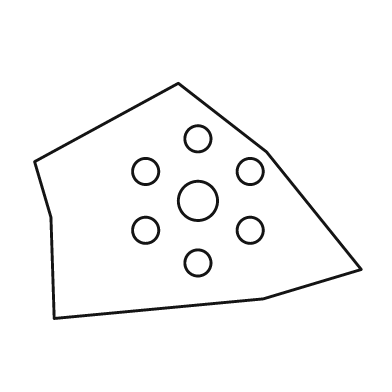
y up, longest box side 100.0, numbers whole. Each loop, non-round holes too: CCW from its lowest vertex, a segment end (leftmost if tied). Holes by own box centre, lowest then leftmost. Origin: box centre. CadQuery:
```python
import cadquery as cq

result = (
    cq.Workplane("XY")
    .moveTo(-44.0, -36.0)
    .lineTo(20.0, -30.0)
    .lineTo(50.0, -21.0)
    .lineTo(21.0, 15.0)
    .lineTo(-6.0, 36.0)
    .lineTo(-50.0, 12.0)
    .lineTo(-45.0, -5.0)
    .close()
    .moveTo(0.0, -19.0)
    .circle(4.0)
    .moveTo(-16.0, -9.0)
    .circle(4.0)
    .moveTo(16.0, -9.0)
    .circle(4.0)
    .moveTo(0.0, 0.0)
    .circle(6.0)
    .moveTo(-16.0, 9.0)
    .circle(4.0)
    .moveTo(16.0, 9.0)
    .circle(4.0)
    .moveTo(0.0, 19.0)
    .circle(4.0)
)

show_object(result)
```